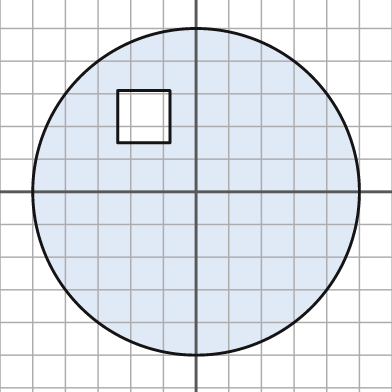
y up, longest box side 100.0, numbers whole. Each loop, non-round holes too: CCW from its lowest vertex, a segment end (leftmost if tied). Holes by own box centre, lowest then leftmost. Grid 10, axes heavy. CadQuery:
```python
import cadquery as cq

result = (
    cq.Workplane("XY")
    .moveTo(0.0, 0.0)
    .circle(50.0)
    .moveTo(-24.0, 15.0)
    .lineTo(-8.0, 15.0)
    .lineTo(-8.0, 31.0)
    .lineTo(-24.0, 31.0)
    .close()
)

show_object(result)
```